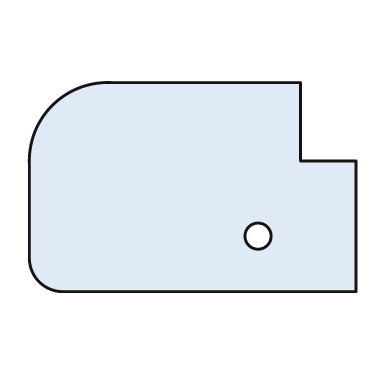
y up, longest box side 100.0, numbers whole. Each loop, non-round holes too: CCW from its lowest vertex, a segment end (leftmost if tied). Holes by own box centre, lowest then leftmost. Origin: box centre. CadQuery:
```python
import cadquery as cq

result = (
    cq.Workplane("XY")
    .moveTo(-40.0, -32.0)
    .lineTo(50.0, -32.0)
    .lineTo(50.0, 8.0)
    .lineTo(33.0, 8.0)
    .lineTo(33.0, 32.0)
    .lineTo(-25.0, 32.0)
    .threePointArc((-43.0, 25.0), (-50.0, 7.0))
    .lineTo(-50.0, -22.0)
    .threePointArc((-47.0, -29.0), (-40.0, -32.0))
    .close()
    .moveTo(20.0, -15.0)
    .circle(4.0)
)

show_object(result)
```